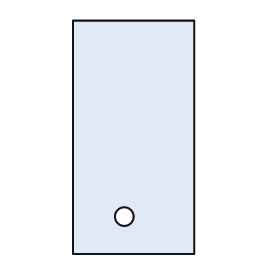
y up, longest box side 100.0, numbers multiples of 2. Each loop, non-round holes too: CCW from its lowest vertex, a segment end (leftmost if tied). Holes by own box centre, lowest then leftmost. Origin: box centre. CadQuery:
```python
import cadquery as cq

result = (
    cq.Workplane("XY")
    .moveTo(-26.0, -50.0)
    .lineTo(26.0, -50.0)
    .lineTo(26.0, 50.0)
    .lineTo(-26.0, 50.0)
    .close()
    .moveTo(-4.0, -34.0)
    .circle(4.0)
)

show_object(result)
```